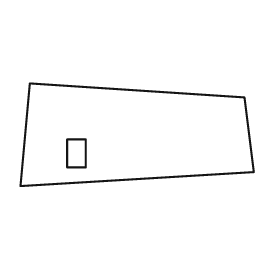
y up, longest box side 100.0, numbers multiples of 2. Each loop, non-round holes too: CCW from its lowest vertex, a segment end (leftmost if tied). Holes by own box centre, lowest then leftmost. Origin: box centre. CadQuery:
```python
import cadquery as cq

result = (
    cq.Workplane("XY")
    .moveTo(-50.0, -22.0)
    .lineTo(50.0, -16.0)
    .lineTo(46.0, 16.0)
    .lineTo(-46.0, 22.0)
    .close()
    .moveTo(-30.0, -14.0)
    .lineTo(-22.0, -14.0)
    .lineTo(-22.0, -2.0)
    .lineTo(-30.0, -2.0)
    .close()
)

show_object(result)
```